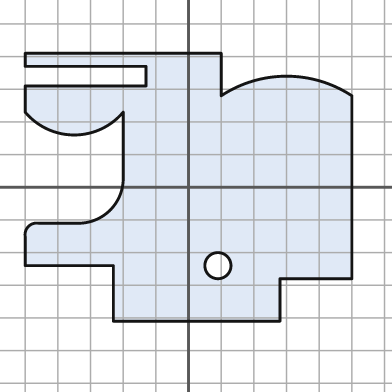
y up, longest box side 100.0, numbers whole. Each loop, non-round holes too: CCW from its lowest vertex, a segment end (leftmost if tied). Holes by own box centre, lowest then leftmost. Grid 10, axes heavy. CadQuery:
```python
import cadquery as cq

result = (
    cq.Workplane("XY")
    .moveTo(-23.0, -41.0)
    .lineTo(28.0, -41.0)
    .lineTo(28.0, -28.0)
    .lineTo(50.0, -28.0)
    .lineTo(50.0, 28.0)
    .threePointArc((30.0, 34.0), (10.0, 28.0))
    .lineTo(10.0, 41.0)
    .lineTo(-50.0, 41.0)
    .lineTo(-50.0, 37.0)
    .lineTo(-13.0, 37.0)
    .lineTo(-13.0, 31.0)
    .lineTo(-50.0, 31.0)
    .lineTo(-50.0, 23.0)
    .threePointArc((-35.0, 16.0), (-20.0, 23.0))
    .lineTo(-20.0, 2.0)
    .threePointArc((-24.0, -7.0), (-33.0, -11.0))
    .lineTo(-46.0, -11.0)
    .threePointArc((-49.0, -12.0), (-50.0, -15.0))
    .lineTo(-50.0, -24.0)
    .lineTo(-23.0, -24.0)
    .close()
    .moveTo(9.0, -24.0)
    .circle(4.0)
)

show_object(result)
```